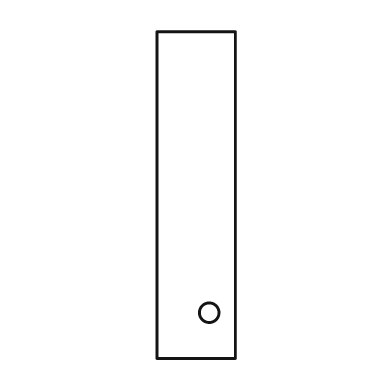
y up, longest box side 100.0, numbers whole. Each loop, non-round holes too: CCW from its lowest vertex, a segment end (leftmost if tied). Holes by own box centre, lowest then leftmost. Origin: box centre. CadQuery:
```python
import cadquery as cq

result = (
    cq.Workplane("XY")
    .moveTo(-12.0, -50.0)
    .lineTo(12.0, -50.0)
    .lineTo(12.0, 50.0)
    .lineTo(-12.0, 50.0)
    .close()
    .moveTo(4.0, -36.0)
    .circle(3.0)
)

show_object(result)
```